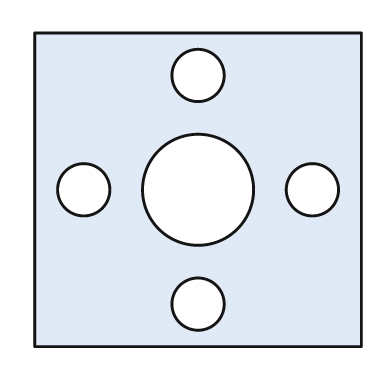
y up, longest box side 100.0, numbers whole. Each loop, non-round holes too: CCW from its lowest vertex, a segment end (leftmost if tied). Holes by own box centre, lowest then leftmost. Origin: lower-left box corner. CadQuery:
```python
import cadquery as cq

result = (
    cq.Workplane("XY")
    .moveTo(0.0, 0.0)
    .lineTo(100.0, 0.0)
    .lineTo(100.0, 96.0)
    .lineTo(0.0, 96.0)
    .close()
    .moveTo(50.0, 13.0)
    .circle(8.0)
    .moveTo(15.0, 48.0)
    .circle(8.0)
    .moveTo(50.0, 48.0)
    .circle(17.0)
    .moveTo(85.0, 48.0)
    .circle(8.0)
    .moveTo(50.0, 83.0)
    .circle(8.0)
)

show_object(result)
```